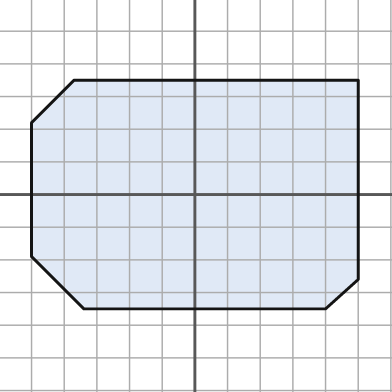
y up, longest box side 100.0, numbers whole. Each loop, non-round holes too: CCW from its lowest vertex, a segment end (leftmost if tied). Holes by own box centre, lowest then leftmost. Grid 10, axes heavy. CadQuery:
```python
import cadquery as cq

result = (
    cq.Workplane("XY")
    .moveTo(-34.0, -35.0)
    .lineTo(40.0, -35.0)
    .lineTo(50.0, -26.0)
    .lineTo(50.0, 35.0)
    .lineTo(-37.0, 35.0)
    .lineTo(-50.0, 22.0)
    .lineTo(-50.0, -19.0)
    .close()
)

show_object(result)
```